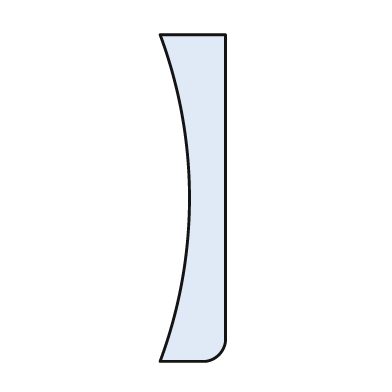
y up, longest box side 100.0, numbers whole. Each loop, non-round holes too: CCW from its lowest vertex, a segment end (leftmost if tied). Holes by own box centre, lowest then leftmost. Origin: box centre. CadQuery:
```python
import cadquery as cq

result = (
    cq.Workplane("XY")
    .moveTo(-10.0, -50.0)
    .lineTo(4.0, -50.0)
    .threePointArc((8.0, -48.0), (10.0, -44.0))
    .lineTo(10.0, 50.0)
    .lineTo(-10.0, 50.0)
    .threePointArc((-1.0, 0.0), (-10.0, -50.0))
    .close()
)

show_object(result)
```